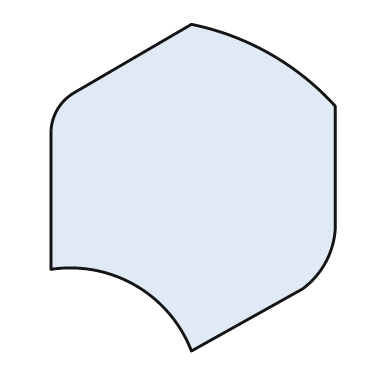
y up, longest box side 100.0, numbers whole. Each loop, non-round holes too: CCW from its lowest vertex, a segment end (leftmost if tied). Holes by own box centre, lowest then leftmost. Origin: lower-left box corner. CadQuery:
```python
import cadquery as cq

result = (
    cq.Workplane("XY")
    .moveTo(43.0, 0.0)
    .lineTo(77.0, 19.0)
    .threePointArc((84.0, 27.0), (87.0, 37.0))
    .lineTo(87.0, 75.0)
    .threePointArc((67.0, 91.0), (43.0, 100.0))
    .lineTo(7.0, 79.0)
    .threePointArc((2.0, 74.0), (0.0, 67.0))
    .lineTo(0.0, 25.0)
    .threePointArc((26.0, 20.0), (43.0, 0.0))
    .close()
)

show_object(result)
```